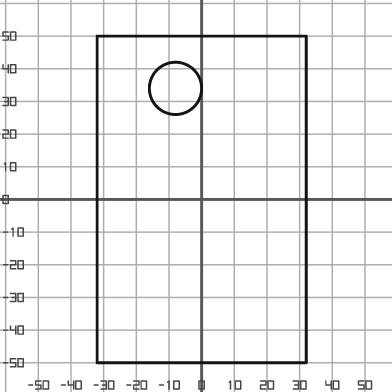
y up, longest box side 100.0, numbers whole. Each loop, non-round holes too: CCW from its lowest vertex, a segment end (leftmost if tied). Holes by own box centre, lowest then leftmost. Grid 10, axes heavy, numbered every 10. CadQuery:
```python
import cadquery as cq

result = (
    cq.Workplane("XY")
    .moveTo(-32.0, -50.0)
    .lineTo(32.0, -50.0)
    .lineTo(32.0, 50.0)
    .lineTo(-32.0, 50.0)
    .close()
    .moveTo(-8.0, 34.0)
    .circle(8.0)
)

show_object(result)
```